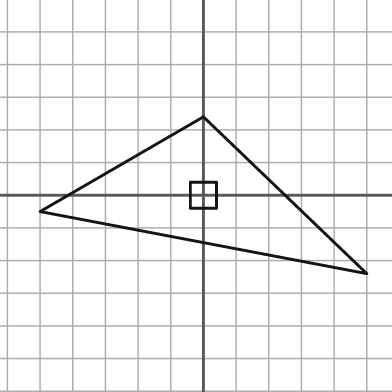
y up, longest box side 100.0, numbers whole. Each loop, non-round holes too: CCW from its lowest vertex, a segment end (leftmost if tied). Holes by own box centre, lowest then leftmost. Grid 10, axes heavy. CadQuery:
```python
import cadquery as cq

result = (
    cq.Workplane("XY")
    .moveTo(50.0, -24.0)
    .lineTo(0.0, 24.0)
    .lineTo(-50.0, -5.0)
    .close()
    .moveTo(-4.0, -4.0)
    .lineTo(4.0, -4.0)
    .lineTo(4.0, 4.0)
    .lineTo(-4.0, 4.0)
    .close()
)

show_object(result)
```